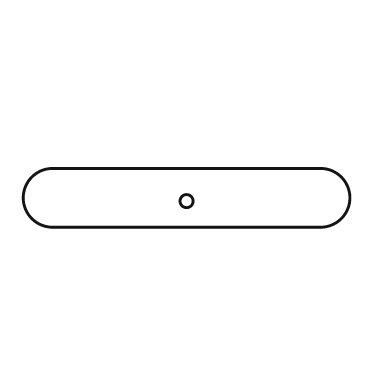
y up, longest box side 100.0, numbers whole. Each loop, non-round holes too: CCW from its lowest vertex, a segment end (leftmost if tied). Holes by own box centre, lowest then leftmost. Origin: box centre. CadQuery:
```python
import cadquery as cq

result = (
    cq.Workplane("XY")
    .moveTo(-41.0, -9.0)
    .lineTo(41.0, -9.0)
    .threePointArc((50.0, 0.0), (41.0, 9.0))
    .lineTo(-41.0, 9.0)
    .threePointArc((-50.0, 0.0), (-41.0, -9.0))
    .close()
    .moveTo(0.0, -1.0)
    .circle(2.0)
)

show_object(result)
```